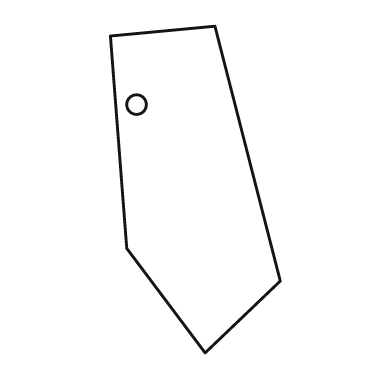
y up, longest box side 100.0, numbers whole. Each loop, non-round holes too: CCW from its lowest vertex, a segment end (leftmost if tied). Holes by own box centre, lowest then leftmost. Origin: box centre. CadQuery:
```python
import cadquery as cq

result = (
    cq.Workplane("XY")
    .moveTo(3.0, -50.0)
    .lineTo(26.0, -28.0)
    .lineTo(6.0, 50.0)
    .lineTo(-26.0, 47.0)
    .lineTo(-21.0, -18.0)
    .close()
    .moveTo(-18.0, 26.0)
    .circle(3.0)
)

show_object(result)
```